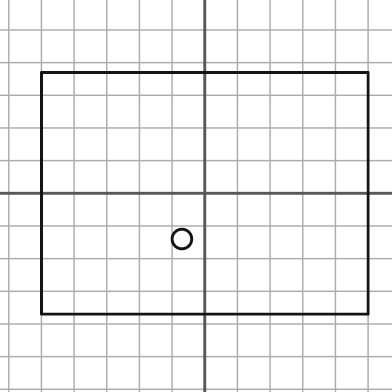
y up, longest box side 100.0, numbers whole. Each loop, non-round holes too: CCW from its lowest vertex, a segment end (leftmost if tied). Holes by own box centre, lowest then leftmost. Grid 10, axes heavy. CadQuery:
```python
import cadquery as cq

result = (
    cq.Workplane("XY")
    .moveTo(-50.0, -37.0)
    .lineTo(50.0, -37.0)
    .lineTo(50.0, 37.0)
    .lineTo(-50.0, 37.0)
    .close()
    .moveTo(-7.0, -14.0)
    .circle(3.0)
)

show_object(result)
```